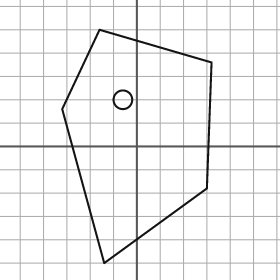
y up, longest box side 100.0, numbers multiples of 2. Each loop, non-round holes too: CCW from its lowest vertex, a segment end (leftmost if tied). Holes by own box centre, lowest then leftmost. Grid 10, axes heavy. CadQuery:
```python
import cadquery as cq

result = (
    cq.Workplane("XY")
    .moveTo(-14.0, -50.0)
    .lineTo(30.0, -18.0)
    .lineTo(32.0, 36.0)
    .lineTo(-16.0, 50.0)
    .lineTo(-32.0, 16.0)
    .close()
    .moveTo(-6.0, 20.0)
    .circle(4.0)
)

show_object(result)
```